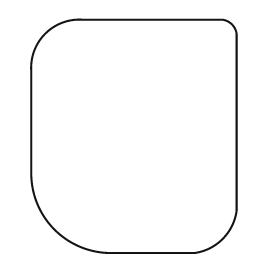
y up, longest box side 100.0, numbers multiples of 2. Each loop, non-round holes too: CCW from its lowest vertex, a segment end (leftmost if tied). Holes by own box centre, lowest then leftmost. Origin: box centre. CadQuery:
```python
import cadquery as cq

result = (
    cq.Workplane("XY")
    .moveTo(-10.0, -50.0)
    .lineTo(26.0, -50.0)
    .threePointArc((38.0, -44.0), (44.0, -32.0))
    .lineTo(44.0, 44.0)
    .threePointArc((42.0, 48.0), (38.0, 50.0))
    .lineTo(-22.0, 50.0)
    .threePointArc((-38.0, 44.0), (-44.0, 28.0))
    .lineTo(-44.0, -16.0)
    .threePointArc((-34.0, -40.0), (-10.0, -50.0))
    .close()
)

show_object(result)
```